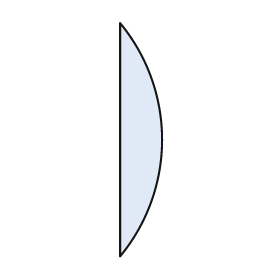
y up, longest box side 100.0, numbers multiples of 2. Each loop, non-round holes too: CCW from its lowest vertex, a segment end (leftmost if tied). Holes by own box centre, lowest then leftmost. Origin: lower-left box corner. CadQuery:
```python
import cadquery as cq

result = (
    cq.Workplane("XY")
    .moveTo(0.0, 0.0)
    .threePointArc((18.0, 50.0), (0.0, 100.0))
    .close()
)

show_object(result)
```